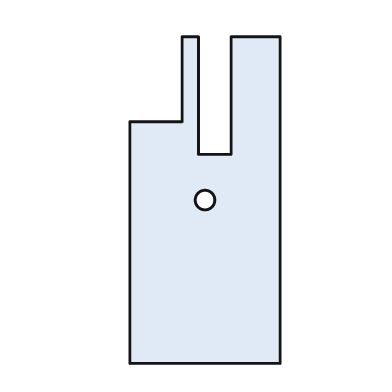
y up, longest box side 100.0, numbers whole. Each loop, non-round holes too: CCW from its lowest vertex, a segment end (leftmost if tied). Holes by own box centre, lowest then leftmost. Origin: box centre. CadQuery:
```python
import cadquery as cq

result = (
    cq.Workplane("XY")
    .moveTo(-23.0, -50.0)
    .lineTo(23.0, -50.0)
    .lineTo(23.0, 50.0)
    .lineTo(8.0, 50.0)
    .lineTo(8.0, 14.0)
    .lineTo(-2.0, 14.0)
    .lineTo(-2.0, 50.0)
    .lineTo(-7.0, 50.0)
    .lineTo(-7.0, 24.0)
    .lineTo(-23.0, 24.0)
    .close()
    .moveTo(0.0, 0.0)
    .circle(3.0)
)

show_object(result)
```